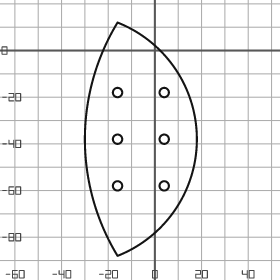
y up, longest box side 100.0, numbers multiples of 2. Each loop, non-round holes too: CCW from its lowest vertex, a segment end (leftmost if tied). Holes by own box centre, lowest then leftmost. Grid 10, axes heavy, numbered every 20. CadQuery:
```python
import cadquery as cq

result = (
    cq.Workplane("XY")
    .moveTo(-16.0, -88.0)
    .threePointArc((18.0, -38.0), (-16.0, 12.0))
    .threePointArc((-30.0, -38.0), (-16.0, -88.0))
    .close()
    .moveTo(-16.0, -58.0)
    .circle(2.0)
    .moveTo(4.0, -58.0)
    .circle(2.0)
    .moveTo(-16.0, -38.0)
    .circle(2.0)
    .moveTo(4.0, -38.0)
    .circle(2.0)
    .moveTo(-16.0, -18.0)
    .circle(2.0)
    .moveTo(4.0, -18.0)
    .circle(2.0)
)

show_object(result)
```